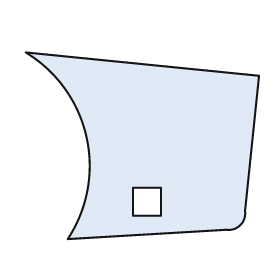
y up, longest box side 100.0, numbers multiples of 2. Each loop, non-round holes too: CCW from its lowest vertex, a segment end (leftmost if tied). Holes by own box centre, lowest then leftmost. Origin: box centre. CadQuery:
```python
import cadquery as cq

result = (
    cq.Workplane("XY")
    .moveTo(-32.0, -40.0)
    .lineTo(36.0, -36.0)
    .threePointArc((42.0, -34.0), (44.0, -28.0))
    .lineTo(50.0, 30.0)
    .lineTo(-50.0, 40.0)
    .threePointArc((-24.0, 4.0), (-32.0, -40.0))
    .close()
    .moveTo(-4.0, -30.0)
    .lineTo(8.0, -30.0)
    .lineTo(8.0, -18.0)
    .lineTo(-4.0, -18.0)
    .close()
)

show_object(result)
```